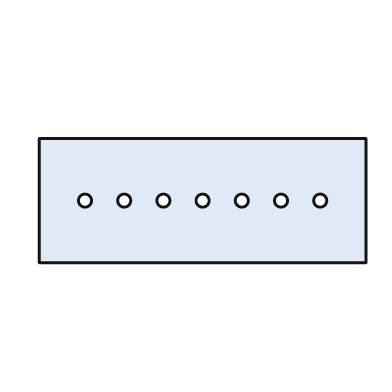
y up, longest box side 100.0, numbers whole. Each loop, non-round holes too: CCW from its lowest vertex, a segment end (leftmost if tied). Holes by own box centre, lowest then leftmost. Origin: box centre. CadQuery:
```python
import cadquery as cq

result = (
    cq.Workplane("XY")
    .moveTo(-50.0, -19.0)
    .lineTo(50.0, -19.0)
    .lineTo(50.0, 19.0)
    .lineTo(-50.0, 19.0)
    .close()
    .moveTo(-36.0, 0.0)
    .circle(2.0)
    .moveTo(-24.0, 0.0)
    .circle(2.0)
    .moveTo(-12.0, 0.0)
    .circle(2.0)
    .moveTo(0.0, 0.0)
    .circle(2.0)
    .moveTo(12.0, 0.0)
    .circle(2.0)
    .moveTo(24.0, 0.0)
    .circle(2.0)
    .moveTo(36.0, 0.0)
    .circle(2.0)
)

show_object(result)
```